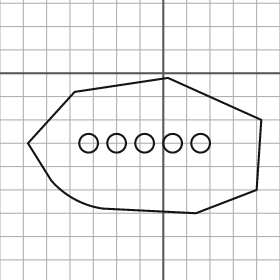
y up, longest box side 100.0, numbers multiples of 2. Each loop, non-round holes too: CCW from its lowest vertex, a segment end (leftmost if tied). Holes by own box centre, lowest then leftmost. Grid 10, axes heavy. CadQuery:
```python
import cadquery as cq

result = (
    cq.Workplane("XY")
    .moveTo(14.0, -60.0)
    .lineTo(40.0, -50.0)
    .lineTo(42.0, -20.0)
    .lineTo(2.0, -2.0)
    .lineTo(-38.0, -8.0)
    .lineTo(-58.0, -30.0)
    .lineTo(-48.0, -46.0)
    .threePointArc((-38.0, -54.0), (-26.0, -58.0))
    .close()
    .moveTo(-32.0, -30.0)
    .circle(4.0)
    .moveTo(-20.0, -30.0)
    .circle(4.0)
    .moveTo(-8.0, -30.0)
    .circle(4.0)
    .moveTo(4.0, -30.0)
    .circle(4.0)
    .moveTo(16.0, -30.0)
    .circle(4.0)
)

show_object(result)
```